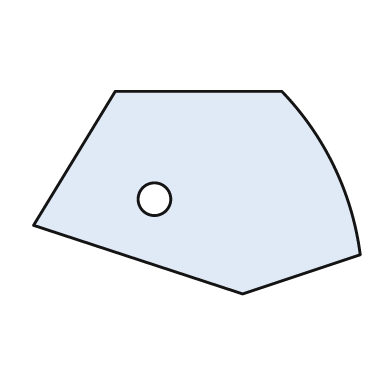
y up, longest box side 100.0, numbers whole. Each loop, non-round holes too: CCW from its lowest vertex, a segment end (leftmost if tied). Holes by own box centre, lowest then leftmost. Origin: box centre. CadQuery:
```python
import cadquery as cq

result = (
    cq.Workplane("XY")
    .moveTo(14.0, -31.0)
    .lineTo(50.0, -19.0)
    .threePointArc((42.0, 8.0), (26.0, 31.0))
    .lineTo(-25.0, 31.0)
    .lineTo(-50.0, -10.0)
    .close()
    .moveTo(-13.0, -2.0)
    .circle(5.0)
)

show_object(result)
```